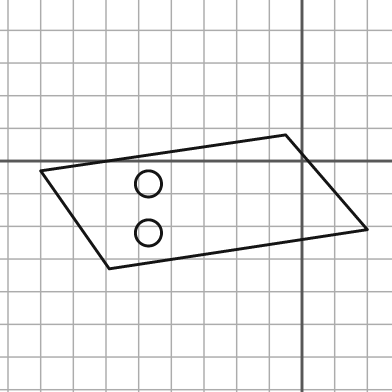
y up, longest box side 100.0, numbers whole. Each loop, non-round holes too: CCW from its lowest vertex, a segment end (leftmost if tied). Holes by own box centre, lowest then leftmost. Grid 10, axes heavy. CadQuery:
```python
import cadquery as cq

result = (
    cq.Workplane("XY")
    .moveTo(-59.0, -33.0)
    .lineTo(20.0, -21.0)
    .lineTo(-5.0, 8.0)
    .lineTo(-80.0, -3.0)
    .close()
    .moveTo(-47.0, -22.0)
    .circle(4.0)
    .moveTo(-47.0, -7.0)
    .circle(4.0)
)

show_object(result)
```